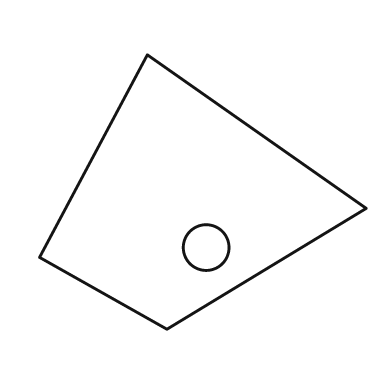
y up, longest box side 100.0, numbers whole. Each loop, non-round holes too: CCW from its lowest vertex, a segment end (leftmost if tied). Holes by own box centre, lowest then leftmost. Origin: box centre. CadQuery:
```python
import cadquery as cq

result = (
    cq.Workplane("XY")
    .moveTo(-11.0, -42.0)
    .lineTo(50.0, -5.0)
    .lineTo(-17.0, 42.0)
    .lineTo(-50.0, -20.0)
    .close()
    .moveTo(1.0, -17.0)
    .circle(7.0)
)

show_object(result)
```